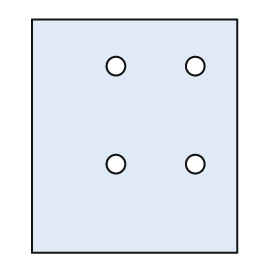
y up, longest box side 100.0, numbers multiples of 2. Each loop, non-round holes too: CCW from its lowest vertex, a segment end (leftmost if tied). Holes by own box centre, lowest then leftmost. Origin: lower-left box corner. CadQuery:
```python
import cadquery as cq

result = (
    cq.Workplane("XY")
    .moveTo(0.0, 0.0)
    .lineTo(88.0, 0.0)
    .lineTo(88.0, 100.0)
    .lineTo(0.0, 100.0)
    .close()
    .moveTo(36.0, 38.0)
    .circle(4.0)
    .moveTo(70.0, 38.0)
    .circle(4.0)
    .moveTo(36.0, 80.0)
    .circle(4.0)
    .moveTo(70.0, 80.0)
    .circle(4.0)
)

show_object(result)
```